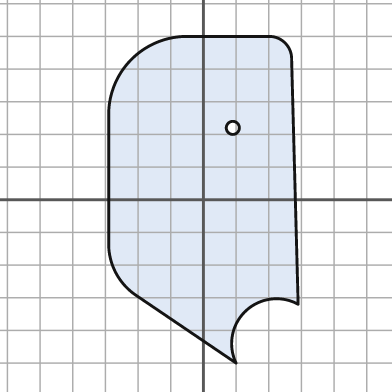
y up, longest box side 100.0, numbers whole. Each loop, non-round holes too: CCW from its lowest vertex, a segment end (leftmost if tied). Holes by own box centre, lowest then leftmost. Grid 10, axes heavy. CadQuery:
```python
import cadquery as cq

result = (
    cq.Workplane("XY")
    .moveTo(10.0, -50.0)
    .threePointArc((13.0, -34.0), (29.0, -32.0))
    .lineTo(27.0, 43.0)
    .threePointArc((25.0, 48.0), (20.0, 50.0))
    .lineTo(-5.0, 50.0)
    .threePointArc((-22.0, 43.0), (-29.0, 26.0))
    .lineTo(-29.0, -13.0)
    .threePointArc((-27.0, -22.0), (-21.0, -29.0))
    .close()
    .moveTo(9.0, 22.0)
    .circle(2.0)
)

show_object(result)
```